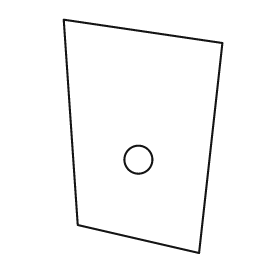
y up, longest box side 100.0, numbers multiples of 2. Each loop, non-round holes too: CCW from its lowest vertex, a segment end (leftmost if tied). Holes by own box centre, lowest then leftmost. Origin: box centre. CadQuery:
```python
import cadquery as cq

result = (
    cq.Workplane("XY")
    .moveTo(24.0, -50.0)
    .lineTo(34.0, 40.0)
    .lineTo(-34.0, 50.0)
    .lineTo(-28.0, -38.0)
    .close()
    .moveTo(-2.0, -10.0)
    .circle(6.0)
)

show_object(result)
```